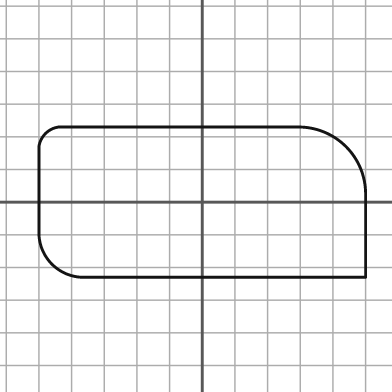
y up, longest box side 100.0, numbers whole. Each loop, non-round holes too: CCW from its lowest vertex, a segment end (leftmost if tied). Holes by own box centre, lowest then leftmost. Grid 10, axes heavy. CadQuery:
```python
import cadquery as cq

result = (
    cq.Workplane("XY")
    .moveTo(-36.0, -23.0)
    .lineTo(50.0, -23.0)
    .lineTo(50.0, 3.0)
    .threePointArc((44.0, 17.0), (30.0, 23.0))
    .lineTo(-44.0, 23.0)
    .threePointArc((-48.0, 21.0), (-50.0, 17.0))
    .lineTo(-50.0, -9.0)
    .threePointArc((-46.0, -19.0), (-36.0, -23.0))
    .close()
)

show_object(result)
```